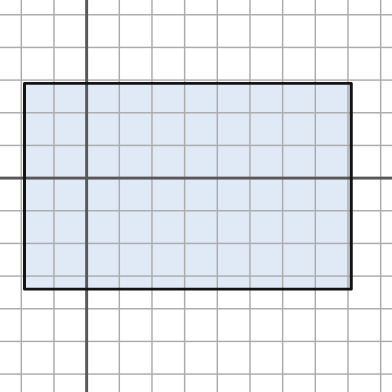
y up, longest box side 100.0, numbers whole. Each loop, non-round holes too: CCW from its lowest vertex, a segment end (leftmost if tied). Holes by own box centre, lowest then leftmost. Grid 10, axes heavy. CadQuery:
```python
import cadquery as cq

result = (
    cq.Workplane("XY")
    .moveTo(-19.0, -34.0)
    .lineTo(81.0, -34.0)
    .lineTo(81.0, 29.0)
    .lineTo(-19.0, 29.0)
    .close()
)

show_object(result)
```